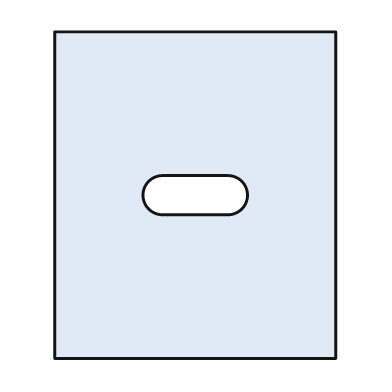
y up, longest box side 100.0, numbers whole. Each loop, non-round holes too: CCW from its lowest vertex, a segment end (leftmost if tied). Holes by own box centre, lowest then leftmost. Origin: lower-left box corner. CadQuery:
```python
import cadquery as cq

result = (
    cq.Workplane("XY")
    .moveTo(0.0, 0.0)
    .lineTo(86.0, 0.0)
    .lineTo(86.0, 100.0)
    .lineTo(0.0, 100.0)
    .close()
    .moveTo(33.0, 44.0)
    .lineTo(53.0, 44.0)
    .threePointArc((59.0, 50.0), (53.0, 56.0))
    .lineTo(33.0, 56.0)
    .threePointArc((27.0, 50.0), (33.0, 44.0))
    .close()
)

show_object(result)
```